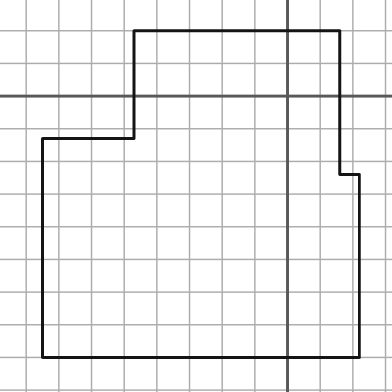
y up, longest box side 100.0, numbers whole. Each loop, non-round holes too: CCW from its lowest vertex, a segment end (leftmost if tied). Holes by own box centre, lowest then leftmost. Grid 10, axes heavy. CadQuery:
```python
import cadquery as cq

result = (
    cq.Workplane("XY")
    .moveTo(-75.0, -80.0)
    .lineTo(22.0, -80.0)
    .lineTo(22.0, -24.0)
    .lineTo(16.0, -24.0)
    .lineTo(16.0, 20.0)
    .lineTo(-47.0, 20.0)
    .lineTo(-47.0, -13.0)
    .lineTo(-75.0, -13.0)
    .close()
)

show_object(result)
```